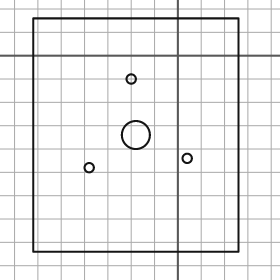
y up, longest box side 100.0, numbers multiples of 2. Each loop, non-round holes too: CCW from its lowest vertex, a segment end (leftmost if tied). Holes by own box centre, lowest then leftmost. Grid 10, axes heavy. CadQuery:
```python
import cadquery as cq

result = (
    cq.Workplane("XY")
    .moveTo(-62.0, -84.0)
    .lineTo(26.0, -84.0)
    .lineTo(26.0, 16.0)
    .lineTo(-62.0, 16.0)
    .close()
    .moveTo(-38.0, -48.0)
    .circle(2.0)
    .moveTo(4.0, -44.0)
    .circle(2.0)
    .moveTo(-18.0, -34.0)
    .circle(6.0)
    .moveTo(-20.0, -10.0)
    .circle(2.0)
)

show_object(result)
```